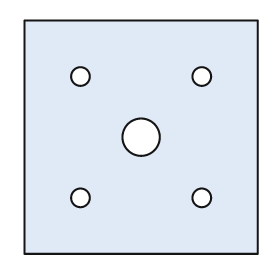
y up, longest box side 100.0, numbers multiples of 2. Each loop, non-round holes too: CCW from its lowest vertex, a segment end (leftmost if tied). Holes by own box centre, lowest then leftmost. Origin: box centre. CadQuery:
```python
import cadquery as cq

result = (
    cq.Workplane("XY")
    .moveTo(-50.0, -50.0)
    .lineTo(50.0, -50.0)
    .lineTo(50.0, 50.0)
    .lineTo(-50.0, 50.0)
    .close()
    .moveTo(-26.0, -26.0)
    .circle(4.0)
    .moveTo(26.0, -26.0)
    .circle(4.0)
    .moveTo(0.0, 0.0)
    .circle(8.0)
    .moveTo(-26.0, 26.0)
    .circle(4.0)
    .moveTo(26.0, 26.0)
    .circle(4.0)
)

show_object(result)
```